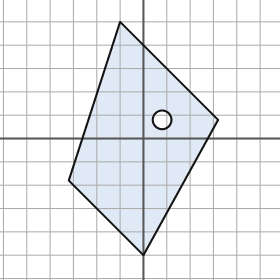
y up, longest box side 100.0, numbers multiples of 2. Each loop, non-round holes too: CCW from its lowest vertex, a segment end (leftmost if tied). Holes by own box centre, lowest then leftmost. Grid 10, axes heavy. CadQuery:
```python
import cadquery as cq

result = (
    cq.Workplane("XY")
    .moveTo(0.0, -50.0)
    .lineTo(32.0, 8.0)
    .lineTo(-10.0, 50.0)
    .lineTo(-32.0, -18.0)
    .close()
    .moveTo(8.0, 8.0)
    .circle(4.0)
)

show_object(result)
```